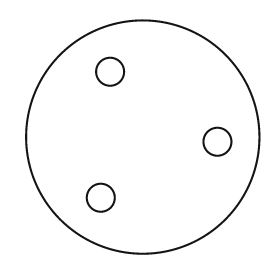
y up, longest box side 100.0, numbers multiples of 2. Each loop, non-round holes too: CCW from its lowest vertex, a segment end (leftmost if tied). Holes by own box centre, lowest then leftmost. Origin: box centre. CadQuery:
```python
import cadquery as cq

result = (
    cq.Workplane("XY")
    .moveTo(0.0, 0.0)
    .circle(50.0)
    .moveTo(-18.0, -26.0)
    .circle(6.0)
    .moveTo(32.0, -2.0)
    .circle(6.0)
    .moveTo(-14.0, 28.0)
    .circle(6.0)
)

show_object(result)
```